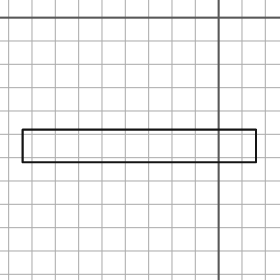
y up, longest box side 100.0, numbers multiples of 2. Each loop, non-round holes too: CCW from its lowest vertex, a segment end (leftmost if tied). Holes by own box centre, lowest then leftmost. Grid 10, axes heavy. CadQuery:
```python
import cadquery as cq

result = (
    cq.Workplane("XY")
    .moveTo(-84.0, -62.0)
    .lineTo(16.0, -62.0)
    .lineTo(16.0, -48.0)
    .lineTo(-84.0, -48.0)
    .close()
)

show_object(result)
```